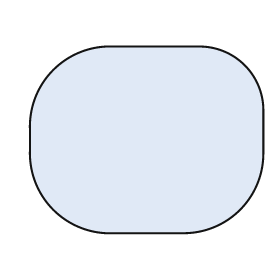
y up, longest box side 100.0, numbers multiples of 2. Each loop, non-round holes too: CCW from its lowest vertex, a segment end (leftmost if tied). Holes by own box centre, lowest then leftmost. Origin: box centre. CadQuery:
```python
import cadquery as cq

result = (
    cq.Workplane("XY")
    .moveTo(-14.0, -40.0)
    .lineTo(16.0, -40.0)
    .threePointArc((40.0, -30.0), (50.0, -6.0))
    .lineTo(50.0, 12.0)
    .threePointArc((42.0, 32.0), (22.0, 40.0))
    .lineTo(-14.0, 40.0)
    .threePointArc((-40.0, 30.0), (-50.0, 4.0))
    .lineTo(-50.0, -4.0)
    .threePointArc((-40.0, -30.0), (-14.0, -40.0))
    .close()
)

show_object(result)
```